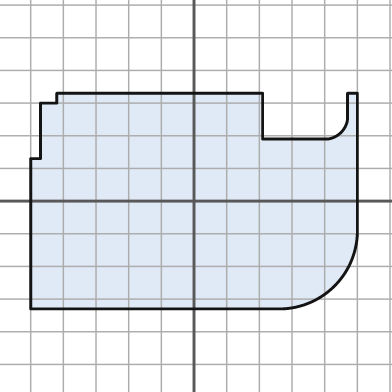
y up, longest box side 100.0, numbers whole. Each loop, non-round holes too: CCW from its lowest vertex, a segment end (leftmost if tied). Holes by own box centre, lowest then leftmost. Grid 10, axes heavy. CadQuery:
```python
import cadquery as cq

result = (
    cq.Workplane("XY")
    .moveTo(-50.0, -33.0)
    .lineTo(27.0, -33.0)
    .threePointArc((43.0, -26.0), (50.0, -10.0))
    .lineTo(50.0, 33.0)
    .lineTo(47.0, 33.0)
    .lineTo(47.0, 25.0)
    .threePointArc((45.0, 21.0), (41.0, 19.0))
    .lineTo(21.0, 19.0)
    .lineTo(21.0, 33.0)
    .lineTo(-42.0, 33.0)
    .lineTo(-42.0, 30.0)
    .lineTo(-47.0, 30.0)
    .lineTo(-47.0, 13.0)
    .lineTo(-50.0, 13.0)
    .close()
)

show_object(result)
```